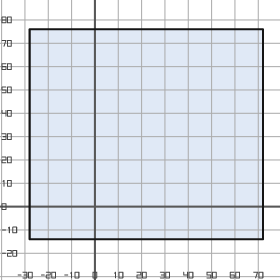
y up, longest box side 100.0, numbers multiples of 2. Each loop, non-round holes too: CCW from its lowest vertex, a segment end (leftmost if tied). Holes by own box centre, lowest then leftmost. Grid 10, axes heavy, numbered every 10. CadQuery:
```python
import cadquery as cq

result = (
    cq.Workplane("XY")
    .moveTo(-28.0, -14.0)
    .lineTo(72.0, -14.0)
    .lineTo(72.0, 76.0)
    .lineTo(-28.0, 76.0)
    .close()
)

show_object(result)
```